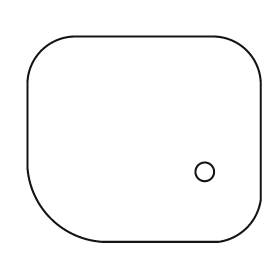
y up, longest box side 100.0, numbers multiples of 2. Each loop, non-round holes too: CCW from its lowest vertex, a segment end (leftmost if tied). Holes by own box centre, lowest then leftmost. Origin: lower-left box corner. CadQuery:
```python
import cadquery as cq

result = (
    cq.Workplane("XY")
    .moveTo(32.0, 0.0)
    .lineTo(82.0, 0.0)
    .threePointArc((94.0, 6.0), (100.0, 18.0))
    .lineTo(100.0, 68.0)
    .threePointArc((94.0, 82.0), (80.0, 88.0))
    .lineTo(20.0, 88.0)
    .threePointArc((6.0, 82.0), (0.0, 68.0))
    .lineTo(0.0, 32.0)
    .threePointArc((10.0, 10.0), (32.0, 0.0))
    .close()
    .moveTo(76.0, 30.0)
    .circle(4.0)
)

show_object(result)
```